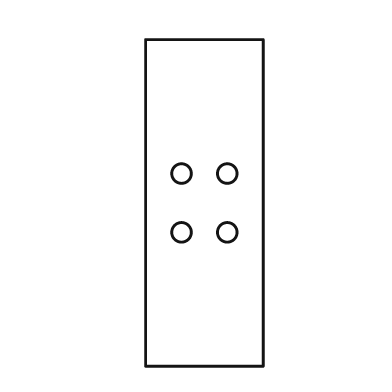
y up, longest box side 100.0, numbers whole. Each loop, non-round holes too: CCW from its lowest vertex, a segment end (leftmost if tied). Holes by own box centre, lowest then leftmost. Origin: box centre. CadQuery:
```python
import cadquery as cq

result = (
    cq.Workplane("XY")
    .moveTo(-18.0, -50.0)
    .lineTo(18.0, -50.0)
    .lineTo(18.0, 50.0)
    .lineTo(-18.0, 50.0)
    .close()
    .moveTo(-7.0, -9.0)
    .circle(3.0)
    .moveTo(7.0, -9.0)
    .circle(3.0)
    .moveTo(-7.0, 9.0)
    .circle(3.0)
    .moveTo(7.0, 9.0)
    .circle(3.0)
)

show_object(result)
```